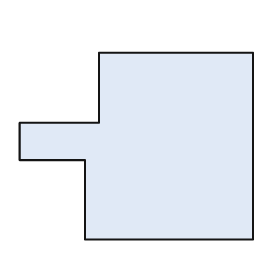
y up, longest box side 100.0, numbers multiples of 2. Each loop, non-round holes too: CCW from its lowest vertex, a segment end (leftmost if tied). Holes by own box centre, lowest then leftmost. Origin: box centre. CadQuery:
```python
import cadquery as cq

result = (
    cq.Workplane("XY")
    .moveTo(-22.0, -40.0)
    .lineTo(50.0, -40.0)
    .lineTo(50.0, 40.0)
    .lineTo(-16.0, 40.0)
    .lineTo(-16.0, 10.0)
    .lineTo(-50.0, 10.0)
    .lineTo(-50.0, -6.0)
    .lineTo(-22.0, -6.0)
    .close()
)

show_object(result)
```